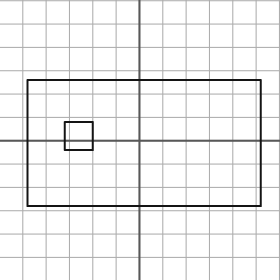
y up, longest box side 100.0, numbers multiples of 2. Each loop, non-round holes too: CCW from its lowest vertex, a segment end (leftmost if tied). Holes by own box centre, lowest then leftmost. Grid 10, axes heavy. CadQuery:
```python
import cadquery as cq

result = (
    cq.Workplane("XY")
    .moveTo(-48.0, -28.0)
    .lineTo(52.0, -28.0)
    .lineTo(52.0, 26.0)
    .lineTo(-48.0, 26.0)
    .close()
    .moveTo(-32.0, -4.0)
    .lineTo(-20.0, -4.0)
    .lineTo(-20.0, 8.0)
    .lineTo(-32.0, 8.0)
    .close()
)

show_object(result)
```